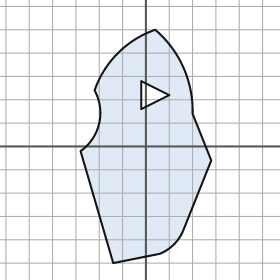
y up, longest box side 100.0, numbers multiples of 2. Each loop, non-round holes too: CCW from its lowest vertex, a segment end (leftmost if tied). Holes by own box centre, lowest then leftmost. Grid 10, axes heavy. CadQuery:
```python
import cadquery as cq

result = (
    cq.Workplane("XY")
    .moveTo(-14.0, -50.0)
    .lineTo(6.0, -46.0)
    .threePointArc((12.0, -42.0), (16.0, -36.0))
    .lineTo(28.0, -6.0)
    .lineTo(20.0, 14.0)
    .threePointArc((16.0, 34.0), (4.0, 50.0))
    .threePointArc((-12.0, 40.0), (-22.0, 24.0))
    .threePointArc((-20.0, 10.0), (-28.0, -2.0))
    .close()
    .moveTo(-2.0, 16.0)
    .lineTo(10.0, 22.0)
    .lineTo(-2.0, 28.0)
    .close()
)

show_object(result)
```